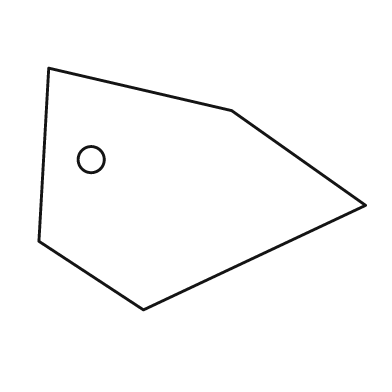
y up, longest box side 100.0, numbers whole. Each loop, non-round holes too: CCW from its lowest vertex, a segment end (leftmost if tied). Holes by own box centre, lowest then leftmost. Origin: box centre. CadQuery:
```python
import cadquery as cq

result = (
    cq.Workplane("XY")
    .moveTo(-18.0, -37.0)
    .lineTo(50.0, -5.0)
    .lineTo(9.0, 24.0)
    .lineTo(-47.0, 37.0)
    .lineTo(-50.0, -16.0)
    .close()
    .moveTo(-34.0, 9.0)
    .circle(4.0)
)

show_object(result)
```